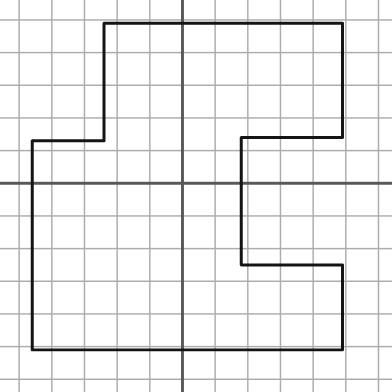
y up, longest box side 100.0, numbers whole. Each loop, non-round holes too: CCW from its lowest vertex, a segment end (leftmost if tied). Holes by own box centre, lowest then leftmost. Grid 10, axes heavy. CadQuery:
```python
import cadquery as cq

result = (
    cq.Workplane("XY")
    .moveTo(-46.0, -51.0)
    .lineTo(49.0, -51.0)
    .lineTo(49.0, -25.0)
    .lineTo(18.0, -25.0)
    .lineTo(18.0, 14.0)
    .lineTo(49.0, 14.0)
    .lineTo(49.0, 49.0)
    .lineTo(-24.0, 49.0)
    .lineTo(-24.0, 13.0)
    .lineTo(-46.0, 13.0)
    .close()
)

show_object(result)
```